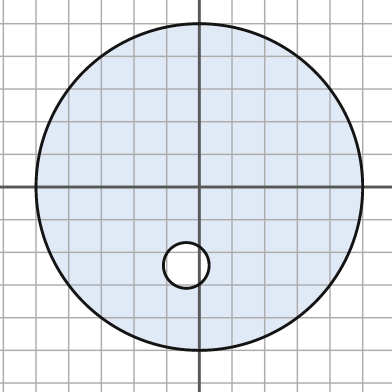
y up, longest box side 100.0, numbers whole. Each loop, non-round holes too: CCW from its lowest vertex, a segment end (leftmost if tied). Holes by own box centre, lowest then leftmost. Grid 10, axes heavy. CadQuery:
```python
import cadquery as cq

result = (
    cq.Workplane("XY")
    .moveTo(0.0, 0.0)
    .circle(50.0)
    .moveTo(-4.0, -24.0)
    .circle(7.0)
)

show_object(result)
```